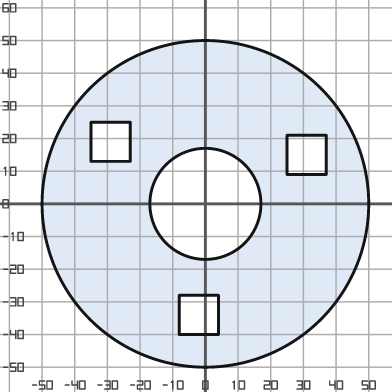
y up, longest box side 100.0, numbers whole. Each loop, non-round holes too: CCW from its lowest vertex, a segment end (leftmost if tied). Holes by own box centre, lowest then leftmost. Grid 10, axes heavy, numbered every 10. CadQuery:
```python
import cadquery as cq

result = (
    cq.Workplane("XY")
    .moveTo(0.0, 0.0)
    .circle(50.0)
    .moveTo(-8.0, -40.0)
    .lineTo(4.0, -40.0)
    .lineTo(4.0, -28.0)
    .lineTo(-8.0, -28.0)
    .close()
    .moveTo(0.0, 0.0)
    .circle(17.0)
    .moveTo(25.0, 9.0)
    .lineTo(37.0, 9.0)
    .lineTo(37.0, 21.0)
    .lineTo(25.0, 21.0)
    .close()
    .moveTo(-35.0, 13.0)
    .lineTo(-23.0, 13.0)
    .lineTo(-23.0, 25.0)
    .lineTo(-35.0, 25.0)
    .close()
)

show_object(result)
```